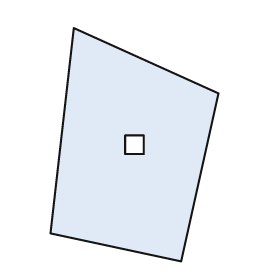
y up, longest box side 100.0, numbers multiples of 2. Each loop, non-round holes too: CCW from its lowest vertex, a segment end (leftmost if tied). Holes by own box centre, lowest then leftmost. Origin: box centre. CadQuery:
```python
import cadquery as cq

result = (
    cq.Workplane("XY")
    .moveTo(20.0, -50.0)
    .lineTo(36.0, 22.0)
    .lineTo(-26.0, 50.0)
    .lineTo(-36.0, -38.0)
    .close()
    .moveTo(-4.0, -4.0)
    .lineTo(4.0, -4.0)
    .lineTo(4.0, 4.0)
    .lineTo(-4.0, 4.0)
    .close()
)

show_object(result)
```